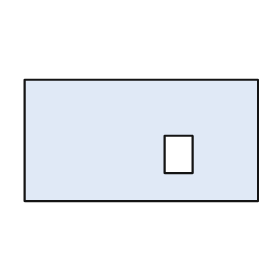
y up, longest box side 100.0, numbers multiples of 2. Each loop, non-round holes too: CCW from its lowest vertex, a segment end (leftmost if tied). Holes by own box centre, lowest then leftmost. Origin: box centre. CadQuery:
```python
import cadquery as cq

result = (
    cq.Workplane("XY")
    .moveTo(-50.0, -26.0)
    .lineTo(50.0, -26.0)
    .lineTo(50.0, 26.0)
    .lineTo(-50.0, 26.0)
    .close()
    .moveTo(10.0, -14.0)
    .lineTo(22.0, -14.0)
    .lineTo(22.0, 2.0)
    .lineTo(10.0, 2.0)
    .close()
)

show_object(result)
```